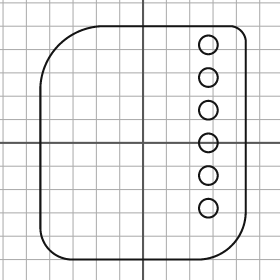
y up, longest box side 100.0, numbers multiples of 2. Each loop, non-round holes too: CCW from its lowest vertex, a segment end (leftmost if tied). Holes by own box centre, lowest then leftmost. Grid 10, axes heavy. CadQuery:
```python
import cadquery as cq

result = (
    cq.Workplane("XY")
    .moveTo(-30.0, -50.0)
    .lineTo(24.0, -50.0)
    .threePointArc((38.0, -44.0), (44.0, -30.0))
    .lineTo(44.0, 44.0)
    .threePointArc((42.0, 48.0), (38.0, 50.0))
    .lineTo(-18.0, 50.0)
    .threePointArc((-36.0, 42.0), (-44.0, 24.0))
    .lineTo(-44.0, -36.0)
    .threePointArc((-40.0, -46.0), (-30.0, -50.0))
    .close()
    .moveTo(28.0, -28.0)
    .circle(4.0)
    .moveTo(28.0, -14.0)
    .circle(4.0)
    .moveTo(28.0, 0.0)
    .circle(4.0)
    .moveTo(28.0, 14.0)
    .circle(4.0)
    .moveTo(28.0, 28.0)
    .circle(4.0)
    .moveTo(28.0, 42.0)
    .circle(4.0)
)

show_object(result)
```